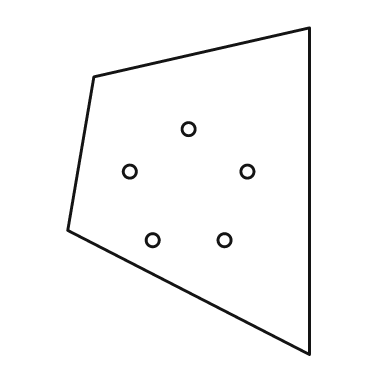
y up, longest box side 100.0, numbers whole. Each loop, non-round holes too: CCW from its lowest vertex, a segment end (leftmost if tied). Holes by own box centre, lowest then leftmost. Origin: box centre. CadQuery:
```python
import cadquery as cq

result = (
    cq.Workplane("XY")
    .moveTo(37.0, -50.0)
    .lineTo(37.0, 50.0)
    .lineTo(-29.0, 35.0)
    .lineTo(-37.0, -12.0)
    .close()
    .moveTo(-11.0, -15.0)
    .circle(2.0)
    .moveTo(11.0, -15.0)
    .circle(2.0)
    .moveTo(-18.0, 6.0)
    .circle(2.0)
    .moveTo(18.0, 6.0)
    .circle(2.0)
    .moveTo(0.0, 19.0)
    .circle(2.0)
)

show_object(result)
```